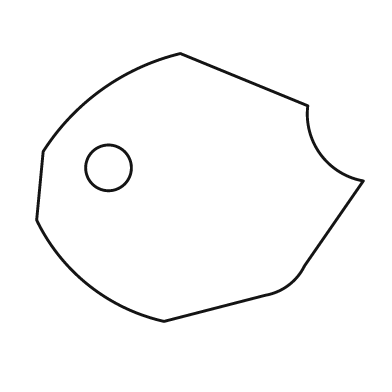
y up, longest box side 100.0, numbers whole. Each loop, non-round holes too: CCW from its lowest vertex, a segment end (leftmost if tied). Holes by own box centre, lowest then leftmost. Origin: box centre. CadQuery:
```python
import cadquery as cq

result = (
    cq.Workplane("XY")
    .moveTo(-11.0, -41.0)
    .lineTo(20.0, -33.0)
    .threePointArc((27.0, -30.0), (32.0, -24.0))
    .lineTo(50.0, 2.0)
    .threePointArc((37.0, 10.0), (33.0, 25.0))
    .lineTo(-6.0, 41.0)
    .threePointArc((-30.0, 30.0), (-48.0, 11.0))
    .lineTo(-50.0, -10.0)
    .threePointArc((-34.0, -30.0), (-11.0, -41.0))
    .close()
    .moveTo(-28.0, 6.0)
    .circle(7.0)
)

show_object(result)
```